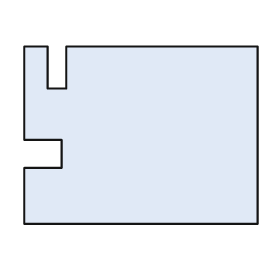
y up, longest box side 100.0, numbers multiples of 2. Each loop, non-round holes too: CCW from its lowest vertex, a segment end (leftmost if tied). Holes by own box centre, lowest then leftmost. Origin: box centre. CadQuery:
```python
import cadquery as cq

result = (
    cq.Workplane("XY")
    .moveTo(-50.0, -38.0)
    .lineTo(50.0, -38.0)
    .lineTo(50.0, 38.0)
    .lineTo(-32.0, 38.0)
    .lineTo(-32.0, 20.0)
    .lineTo(-40.0, 20.0)
    .lineTo(-40.0, 38.0)
    .lineTo(-50.0, 38.0)
    .lineTo(-50.0, -2.0)
    .lineTo(-34.0, -2.0)
    .lineTo(-34.0, -14.0)
    .lineTo(-50.0, -14.0)
    .close()
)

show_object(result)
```